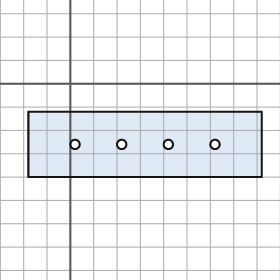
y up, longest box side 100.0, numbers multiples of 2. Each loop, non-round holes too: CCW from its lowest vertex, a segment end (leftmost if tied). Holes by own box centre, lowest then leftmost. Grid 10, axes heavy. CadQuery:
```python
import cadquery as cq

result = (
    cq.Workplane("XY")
    .moveTo(-18.0, -40.0)
    .lineTo(82.0, -40.0)
    .lineTo(82.0, -12.0)
    .lineTo(-18.0, -12.0)
    .close()
    .moveTo(2.0, -26.0)
    .circle(2.0)
    .moveTo(22.0, -26.0)
    .circle(2.0)
    .moveTo(42.0, -26.0)
    .circle(2.0)
    .moveTo(62.0, -26.0)
    .circle(2.0)
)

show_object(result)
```